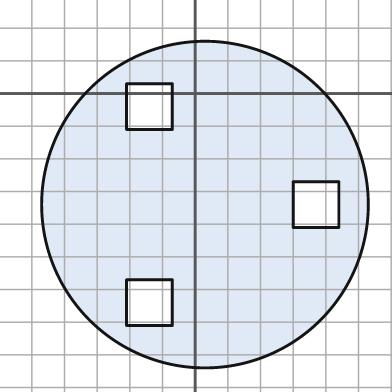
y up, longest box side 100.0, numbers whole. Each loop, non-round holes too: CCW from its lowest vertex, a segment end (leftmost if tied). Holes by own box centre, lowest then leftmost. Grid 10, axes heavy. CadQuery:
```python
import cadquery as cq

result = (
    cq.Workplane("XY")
    .moveTo(3.0, -34.0)
    .circle(50.0)
    .moveTo(-21.0, -71.0)
    .lineTo(-7.0, -71.0)
    .lineTo(-7.0, -57.0)
    .lineTo(-21.0, -57.0)
    .close()
    .moveTo(30.0, -41.0)
    .lineTo(44.0, -41.0)
    .lineTo(44.0, -27.0)
    .lineTo(30.0, -27.0)
    .close()
    .moveTo(-21.0, -11.0)
    .lineTo(-7.0, -11.0)
    .lineTo(-7.0, 3.0)
    .lineTo(-21.0, 3.0)
    .close()
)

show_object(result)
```